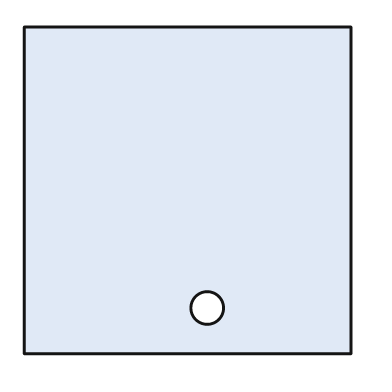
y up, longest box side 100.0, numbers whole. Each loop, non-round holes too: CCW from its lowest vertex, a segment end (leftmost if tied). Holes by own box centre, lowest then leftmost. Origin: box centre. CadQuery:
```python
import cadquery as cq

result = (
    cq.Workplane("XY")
    .moveTo(-50.0, -50.0)
    .lineTo(50.0, -50.0)
    .lineTo(50.0, 50.0)
    .lineTo(-50.0, 50.0)
    .close()
    .moveTo(6.0, -36.0)
    .circle(5.0)
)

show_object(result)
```